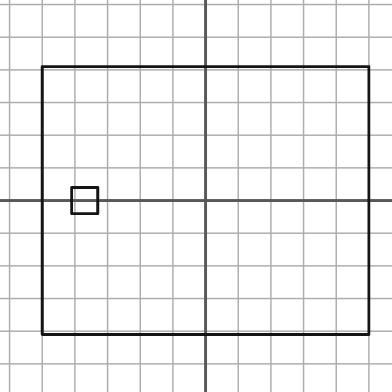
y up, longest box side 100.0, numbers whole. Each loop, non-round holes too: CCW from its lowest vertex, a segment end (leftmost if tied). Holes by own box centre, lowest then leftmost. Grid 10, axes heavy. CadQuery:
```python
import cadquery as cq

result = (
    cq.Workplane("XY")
    .moveTo(-50.0, -41.0)
    .lineTo(50.0, -41.0)
    .lineTo(50.0, 41.0)
    .lineTo(-50.0, 41.0)
    .close()
    .moveTo(-41.0, -4.0)
    .lineTo(-33.0, -4.0)
    .lineTo(-33.0, 4.0)
    .lineTo(-41.0, 4.0)
    .close()
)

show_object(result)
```